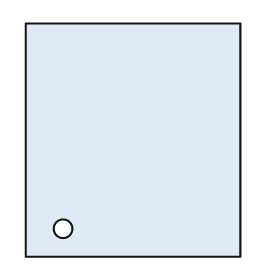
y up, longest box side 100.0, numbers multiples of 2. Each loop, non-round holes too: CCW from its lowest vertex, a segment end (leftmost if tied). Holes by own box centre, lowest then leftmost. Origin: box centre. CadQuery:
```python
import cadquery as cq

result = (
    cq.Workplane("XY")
    .moveTo(-46.0, -50.0)
    .lineTo(46.0, -50.0)
    .lineTo(46.0, 50.0)
    .lineTo(-46.0, 50.0)
    .close()
    .moveTo(-30.0, -38.0)
    .circle(4.0)
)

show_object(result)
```